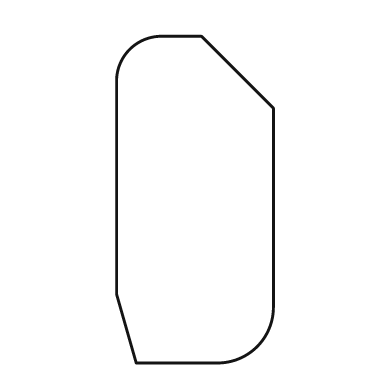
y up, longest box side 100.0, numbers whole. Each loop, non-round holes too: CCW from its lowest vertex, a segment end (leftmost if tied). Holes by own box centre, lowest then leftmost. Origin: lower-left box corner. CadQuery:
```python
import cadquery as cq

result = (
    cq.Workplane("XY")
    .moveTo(6.0, 0.0)
    .lineTo(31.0, 0.0)
    .threePointArc((43.0, 5.0), (48.0, 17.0))
    .lineTo(48.0, 78.0)
    .lineTo(26.0, 100.0)
    .lineTo(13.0, 100.0)
    .threePointArc((4.0, 96.0), (0.0, 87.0))
    .lineTo(0.0, 21.0)
    .close()
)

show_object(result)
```